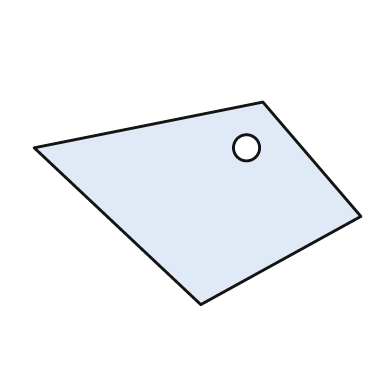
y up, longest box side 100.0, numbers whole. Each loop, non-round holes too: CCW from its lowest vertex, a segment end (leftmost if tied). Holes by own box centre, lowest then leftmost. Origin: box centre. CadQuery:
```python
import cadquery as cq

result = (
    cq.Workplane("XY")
    .moveTo(1.0, -31.0)
    .lineTo(50.0, -4.0)
    .lineTo(20.0, 31.0)
    .lineTo(-50.0, 17.0)
    .close()
    .moveTo(15.0, 17.0)
    .circle(4.0)
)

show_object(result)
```